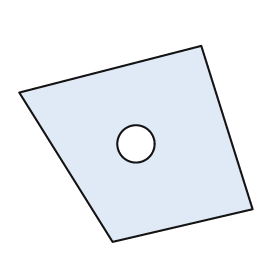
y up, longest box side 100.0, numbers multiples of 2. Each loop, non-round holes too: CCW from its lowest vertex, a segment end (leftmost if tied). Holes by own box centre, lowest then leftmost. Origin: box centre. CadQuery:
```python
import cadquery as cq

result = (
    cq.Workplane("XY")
    .moveTo(-10.0, -42.0)
    .lineTo(50.0, -28.0)
    .lineTo(28.0, 42.0)
    .lineTo(-50.0, 22.0)
    .close()
    .moveTo(0.0, 0.0)
    .circle(8.0)
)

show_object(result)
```